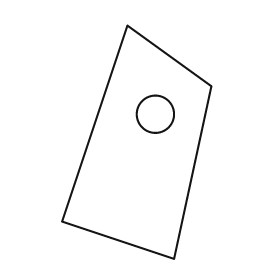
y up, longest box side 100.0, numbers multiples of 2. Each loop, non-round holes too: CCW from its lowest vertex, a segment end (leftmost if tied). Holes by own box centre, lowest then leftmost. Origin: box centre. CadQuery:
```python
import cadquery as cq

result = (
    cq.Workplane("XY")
    .moveTo(16.0, -50.0)
    .lineTo(32.0, 24.0)
    .lineTo(-4.0, 50.0)
    .lineTo(-32.0, -34.0)
    .close()
    .moveTo(8.0, 12.0)
    .circle(8.0)
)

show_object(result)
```